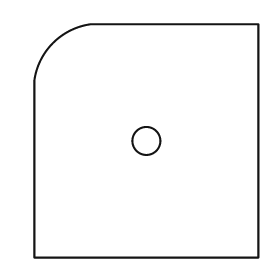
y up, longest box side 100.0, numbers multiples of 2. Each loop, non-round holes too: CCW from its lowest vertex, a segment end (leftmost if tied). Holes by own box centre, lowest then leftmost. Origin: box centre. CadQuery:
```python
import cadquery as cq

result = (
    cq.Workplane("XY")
    .moveTo(-48.0, -50.0)
    .lineTo(48.0, -50.0)
    .lineTo(48.0, 50.0)
    .lineTo(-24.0, 50.0)
    .threePointArc((-40.0, 42.0), (-48.0, 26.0))
    .close()
    .moveTo(0.0, 0.0)
    .circle(6.0)
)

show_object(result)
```